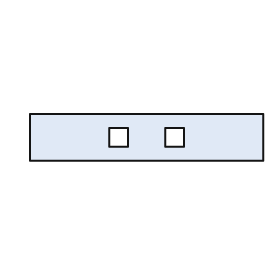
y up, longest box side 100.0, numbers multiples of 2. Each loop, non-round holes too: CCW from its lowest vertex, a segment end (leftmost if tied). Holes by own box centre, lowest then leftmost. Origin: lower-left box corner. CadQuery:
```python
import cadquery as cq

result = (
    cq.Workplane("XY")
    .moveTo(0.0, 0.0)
    .lineTo(100.0, 0.0)
    .lineTo(100.0, 20.0)
    .lineTo(0.0, 20.0)
    .close()
    .moveTo(34.0, 6.0)
    .lineTo(42.0, 6.0)
    .lineTo(42.0, 14.0)
    .lineTo(34.0, 14.0)
    .close()
    .moveTo(58.0, 6.0)
    .lineTo(66.0, 6.0)
    .lineTo(66.0, 14.0)
    .lineTo(58.0, 14.0)
    .close()
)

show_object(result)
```